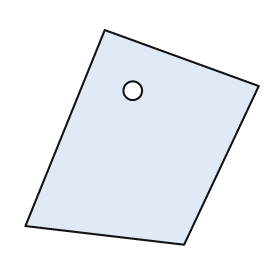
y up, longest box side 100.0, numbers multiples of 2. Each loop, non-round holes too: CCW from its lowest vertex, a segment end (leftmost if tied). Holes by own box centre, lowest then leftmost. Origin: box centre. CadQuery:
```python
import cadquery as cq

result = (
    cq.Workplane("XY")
    .moveTo(18.0, -46.0)
    .lineTo(50.0, 22.0)
    .lineTo(-16.0, 46.0)
    .lineTo(-50.0, -38.0)
    .close()
    .moveTo(-4.0, 20.0)
    .circle(4.0)
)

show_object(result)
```